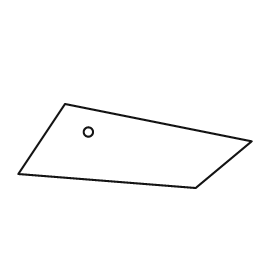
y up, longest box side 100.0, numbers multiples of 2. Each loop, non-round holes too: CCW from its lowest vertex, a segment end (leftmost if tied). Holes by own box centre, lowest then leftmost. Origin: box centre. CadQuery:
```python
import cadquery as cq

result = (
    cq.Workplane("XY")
    .moveTo(26.0, -18.0)
    .lineTo(50.0, 2.0)
    .lineTo(-30.0, 18.0)
    .lineTo(-50.0, -12.0)
    .close()
    .moveTo(-20.0, 6.0)
    .circle(2.0)
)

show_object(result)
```